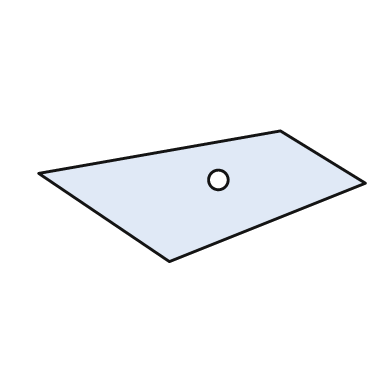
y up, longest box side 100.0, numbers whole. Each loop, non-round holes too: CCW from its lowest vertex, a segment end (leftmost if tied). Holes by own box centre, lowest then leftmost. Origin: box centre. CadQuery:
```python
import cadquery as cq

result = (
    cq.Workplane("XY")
    .moveTo(-10.0, -20.0)
    .lineTo(50.0, 4.0)
    .lineTo(24.0, 20.0)
    .lineTo(-50.0, 7.0)
    .close()
    .moveTo(5.0, 5.0)
    .circle(3.0)
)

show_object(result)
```